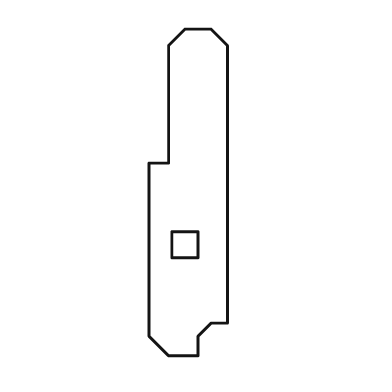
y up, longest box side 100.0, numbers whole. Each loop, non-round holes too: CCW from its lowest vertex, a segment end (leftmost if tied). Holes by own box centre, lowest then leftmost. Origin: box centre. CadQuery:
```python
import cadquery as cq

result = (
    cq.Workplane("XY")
    .moveTo(-6.0, -50.0)
    .lineTo(3.0, -50.0)
    .lineTo(3.0, -44.0)
    .lineTo(7.0, -40.0)
    .lineTo(12.0, -40.0)
    .lineTo(12.0, 45.0)
    .lineTo(7.0, 50.0)
    .lineTo(-1.0, 50.0)
    .lineTo(-6.0, 45.0)
    .lineTo(-6.0, 9.0)
    .lineTo(-12.0, 9.0)
    .lineTo(-12.0, -44.0)
    .close()
    .moveTo(-5.0, -20.0)
    .lineTo(3.0, -20.0)
    .lineTo(3.0, -12.0)
    .lineTo(-5.0, -12.0)
    .close()
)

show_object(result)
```